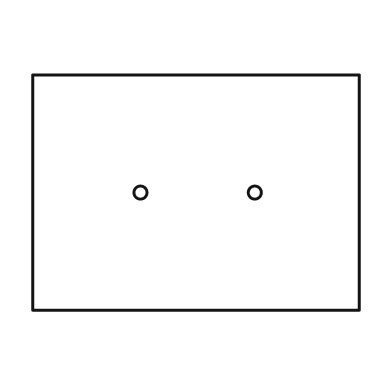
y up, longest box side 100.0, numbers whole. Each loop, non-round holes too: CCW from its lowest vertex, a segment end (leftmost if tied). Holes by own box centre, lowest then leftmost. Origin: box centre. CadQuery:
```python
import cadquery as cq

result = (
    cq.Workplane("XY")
    .moveTo(-50.0, -36.0)
    .lineTo(50.0, -36.0)
    .lineTo(50.0, 36.0)
    .lineTo(-50.0, 36.0)
    .close()
    .moveTo(-17.0, 0.0)
    .circle(2.0)
    .moveTo(18.0, 0.0)
    .circle(2.0)
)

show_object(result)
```